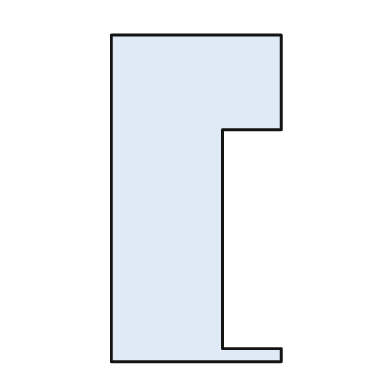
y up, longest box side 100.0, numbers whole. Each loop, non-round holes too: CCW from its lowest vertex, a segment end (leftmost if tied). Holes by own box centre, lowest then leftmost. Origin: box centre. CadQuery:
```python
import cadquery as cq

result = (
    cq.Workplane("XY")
    .moveTo(-26.0, -50.0)
    .lineTo(26.0, -50.0)
    .lineTo(26.0, -46.0)
    .lineTo(8.0, -46.0)
    .lineTo(8.0, 21.0)
    .lineTo(26.0, 21.0)
    .lineTo(26.0, 50.0)
    .lineTo(-26.0, 50.0)
    .close()
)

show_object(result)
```